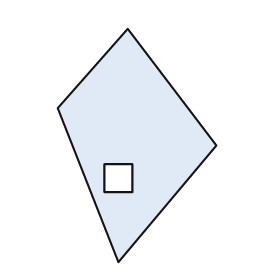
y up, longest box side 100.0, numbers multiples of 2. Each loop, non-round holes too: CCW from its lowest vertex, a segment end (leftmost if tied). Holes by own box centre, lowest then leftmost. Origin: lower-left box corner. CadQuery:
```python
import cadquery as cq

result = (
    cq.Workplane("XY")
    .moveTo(26.0, 0.0)
    .lineTo(68.0, 50.0)
    .lineTo(30.0, 100.0)
    .lineTo(0.0, 66.0)
    .close()
    .moveTo(20.0, 30.0)
    .lineTo(32.0, 30.0)
    .lineTo(32.0, 42.0)
    .lineTo(20.0, 42.0)
    .close()
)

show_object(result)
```